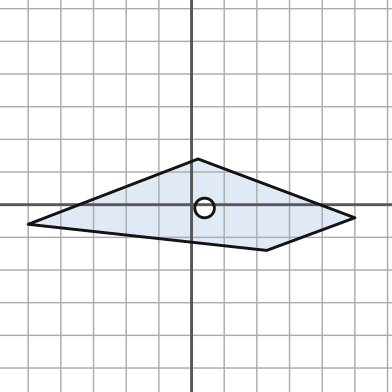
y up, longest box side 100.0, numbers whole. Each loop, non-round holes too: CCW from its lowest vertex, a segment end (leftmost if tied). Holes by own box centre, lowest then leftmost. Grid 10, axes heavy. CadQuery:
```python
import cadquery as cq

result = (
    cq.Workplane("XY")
    .moveTo(23.0, -14.0)
    .lineTo(50.0, -4.0)
    .lineTo(2.0, 14.0)
    .lineTo(-50.0, -6.0)
    .close()
    .moveTo(4.0, -1.0)
    .circle(3.0)
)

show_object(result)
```